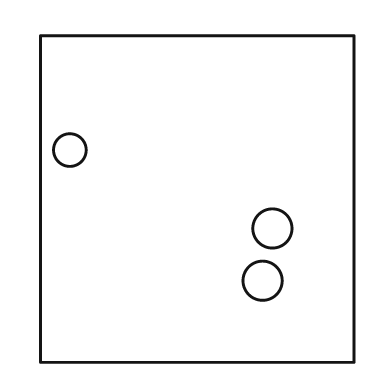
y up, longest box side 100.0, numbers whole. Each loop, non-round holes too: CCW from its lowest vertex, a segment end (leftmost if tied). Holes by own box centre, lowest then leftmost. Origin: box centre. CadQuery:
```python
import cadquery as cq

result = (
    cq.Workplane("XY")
    .moveTo(-48.0, -50.0)
    .lineTo(48.0, -50.0)
    .lineTo(48.0, 50.0)
    .lineTo(-48.0, 50.0)
    .close()
    .moveTo(20.0, -25.0)
    .circle(6.0)
    .moveTo(23.0, -9.0)
    .circle(6.0)
    .moveTo(-39.0, 15.0)
    .circle(5.0)
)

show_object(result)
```